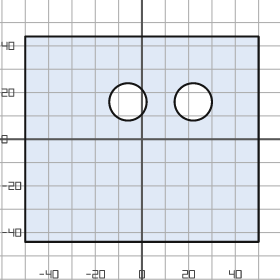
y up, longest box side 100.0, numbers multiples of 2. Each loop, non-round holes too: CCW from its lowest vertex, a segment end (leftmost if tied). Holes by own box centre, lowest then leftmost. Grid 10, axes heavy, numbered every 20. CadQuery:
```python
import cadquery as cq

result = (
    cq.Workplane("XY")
    .moveTo(-50.0, -44.0)
    .lineTo(50.0, -44.0)
    .lineTo(50.0, 44.0)
    .lineTo(-50.0, 44.0)
    .close()
    .moveTo(-6.0, 16.0)
    .circle(8.0)
    .moveTo(22.0, 16.0)
    .circle(8.0)
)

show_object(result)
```